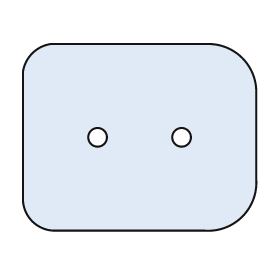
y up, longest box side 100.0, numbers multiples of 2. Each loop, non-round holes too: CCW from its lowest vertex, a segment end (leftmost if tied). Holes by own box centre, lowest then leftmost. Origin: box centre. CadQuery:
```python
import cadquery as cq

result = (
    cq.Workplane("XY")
    .moveTo(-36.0, -40.0)
    .lineTo(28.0, -40.0)
    .threePointArc((44.0, -34.0), (50.0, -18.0))
    .lineTo(50.0, 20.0)
    .threePointArc((44.0, 34.0), (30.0, 40.0))
    .lineTo(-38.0, 40.0)
    .threePointArc((-46.0, 36.0), (-50.0, 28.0))
    .lineTo(-50.0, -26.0)
    .threePointArc((-46.0, -36.0), (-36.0, -40.0))
    .close()
    .moveTo(-18.0, 0.0)
    .circle(4.0)
    .moveTo(18.0, 0.0)
    .circle(4.0)
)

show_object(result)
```